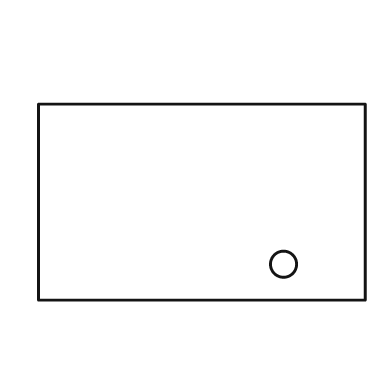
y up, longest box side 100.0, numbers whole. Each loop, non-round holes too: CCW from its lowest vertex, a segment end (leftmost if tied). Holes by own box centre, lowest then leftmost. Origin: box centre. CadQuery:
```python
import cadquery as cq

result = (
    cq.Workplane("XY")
    .moveTo(-50.0, -30.0)
    .lineTo(50.0, -30.0)
    .lineTo(50.0, 30.0)
    .lineTo(-50.0, 30.0)
    .close()
    .moveTo(25.0, -19.0)
    .circle(4.0)
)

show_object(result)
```